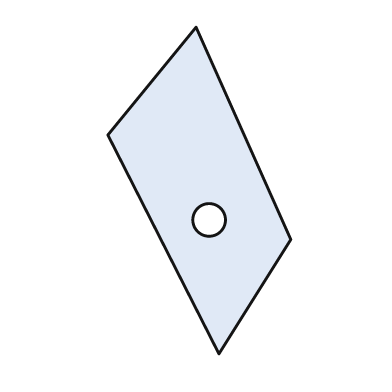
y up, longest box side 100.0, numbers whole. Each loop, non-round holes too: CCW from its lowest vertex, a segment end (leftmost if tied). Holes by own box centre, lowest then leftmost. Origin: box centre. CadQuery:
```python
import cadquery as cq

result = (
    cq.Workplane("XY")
    .moveTo(6.0, -50.0)
    .lineTo(28.0, -15.0)
    .lineTo(-1.0, 50.0)
    .lineTo(-28.0, 17.0)
    .close()
    .moveTo(3.0, -9.0)
    .circle(5.0)
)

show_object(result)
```